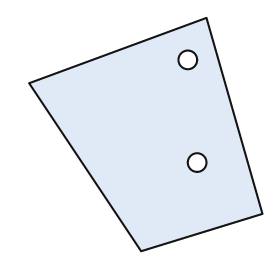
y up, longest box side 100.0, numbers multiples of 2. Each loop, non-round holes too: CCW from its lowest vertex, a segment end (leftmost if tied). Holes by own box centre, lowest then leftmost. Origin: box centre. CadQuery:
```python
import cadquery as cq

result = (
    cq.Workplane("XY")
    .moveTo(-2.0, -50.0)
    .lineTo(50.0, -34.0)
    .lineTo(26.0, 50.0)
    .lineTo(-50.0, 22.0)
    .close()
    .moveTo(22.0, -12.0)
    .circle(4.0)
    .moveTo(18.0, 32.0)
    .circle(4.0)
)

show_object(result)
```